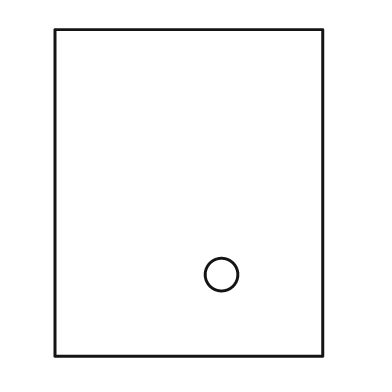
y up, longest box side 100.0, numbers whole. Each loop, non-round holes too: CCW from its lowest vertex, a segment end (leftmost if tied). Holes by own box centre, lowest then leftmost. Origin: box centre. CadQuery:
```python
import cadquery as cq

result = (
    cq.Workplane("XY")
    .moveTo(-41.0, -50.0)
    .lineTo(41.0, -50.0)
    .lineTo(41.0, 50.0)
    .lineTo(-41.0, 50.0)
    .close()
    .moveTo(10.0, -25.0)
    .circle(5.0)
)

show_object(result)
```